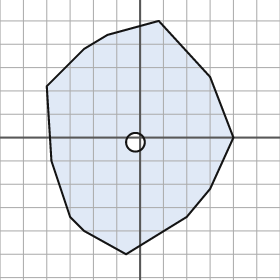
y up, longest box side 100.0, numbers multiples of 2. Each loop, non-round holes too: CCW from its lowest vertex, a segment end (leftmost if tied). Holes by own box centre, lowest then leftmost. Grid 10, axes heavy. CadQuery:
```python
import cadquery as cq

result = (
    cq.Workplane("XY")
    .moveTo(-6.0, -50.0)
    .lineTo(20.0, -34.0)
    .lineTo(30.0, -22.0)
    .lineTo(40.0, 0.0)
    .lineTo(30.0, 26.0)
    .lineTo(8.0, 50.0)
    .lineTo(-14.0, 44.0)
    .lineTo(-24.0, 38.0)
    .lineTo(-40.0, 22.0)
    .lineTo(-38.0, -10.0)
    .lineTo(-30.0, -34.0)
    .lineTo(-24.0, -40.0)
    .close()
    .moveTo(-2.0, -2.0)
    .circle(4.0)
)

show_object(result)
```